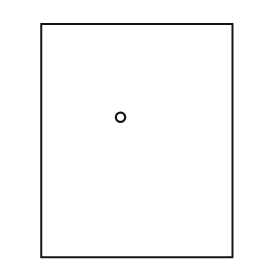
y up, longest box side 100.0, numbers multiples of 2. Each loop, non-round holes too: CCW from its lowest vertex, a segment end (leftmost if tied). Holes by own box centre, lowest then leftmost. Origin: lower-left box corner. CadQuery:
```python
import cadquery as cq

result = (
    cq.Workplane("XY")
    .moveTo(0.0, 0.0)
    .lineTo(82.0, 0.0)
    .lineTo(82.0, 100.0)
    .lineTo(0.0, 100.0)
    .close()
    .moveTo(34.0, 60.0)
    .circle(2.0)
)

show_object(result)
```